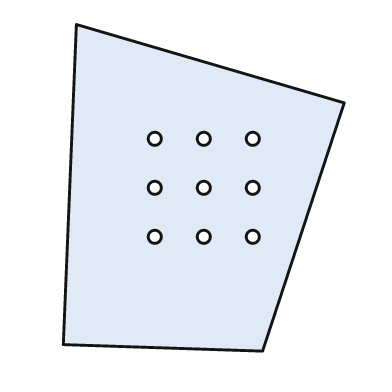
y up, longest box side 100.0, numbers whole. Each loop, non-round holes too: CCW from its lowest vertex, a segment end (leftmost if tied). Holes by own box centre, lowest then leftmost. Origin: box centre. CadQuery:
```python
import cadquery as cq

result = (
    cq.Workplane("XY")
    .moveTo(18.0, -50.0)
    .lineTo(43.0, 26.0)
    .lineTo(-39.0, 50.0)
    .lineTo(-43.0, -48.0)
    .close()
    .moveTo(-15.0, -15.0)
    .circle(2.0)
    .moveTo(0.0, -15.0)
    .circle(2.0)
    .moveTo(15.0, -15.0)
    .circle(2.0)
    .moveTo(-15.0, 0.0)
    .circle(2.0)
    .moveTo(0.0, 0.0)
    .circle(2.0)
    .moveTo(15.0, 0.0)
    .circle(2.0)
    .moveTo(-15.0, 15.0)
    .circle(2.0)
    .moveTo(0.0, 15.0)
    .circle(2.0)
    .moveTo(15.0, 15.0)
    .circle(2.0)
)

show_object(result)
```